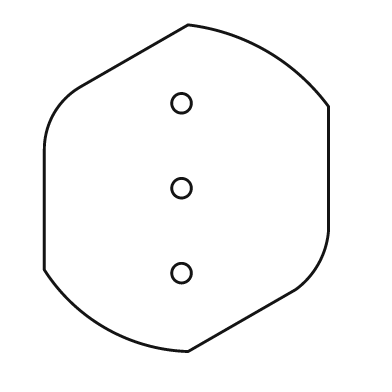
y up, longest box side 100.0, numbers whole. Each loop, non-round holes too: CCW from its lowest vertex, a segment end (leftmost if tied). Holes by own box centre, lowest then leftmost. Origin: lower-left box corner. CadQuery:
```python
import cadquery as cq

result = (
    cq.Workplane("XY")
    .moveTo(44.0, 0.0)
    .lineTo(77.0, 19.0)
    .threePointArc((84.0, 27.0), (87.0, 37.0))
    .lineTo(87.0, 75.0)
    .threePointArc((68.0, 92.0), (44.0, 100.0))
    .lineTo(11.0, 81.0)
    .threePointArc((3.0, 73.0), (0.0, 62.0))
    .lineTo(0.0, 25.0)
    .threePointArc((19.0, 7.0), (44.0, 0.0))
    .close()
    .moveTo(42.0, 24.0)
    .circle(3.0)
    .moveTo(42.0, 50.0)
    .circle(3.0)
    .moveTo(42.0, 76.0)
    .circle(3.0)
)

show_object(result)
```